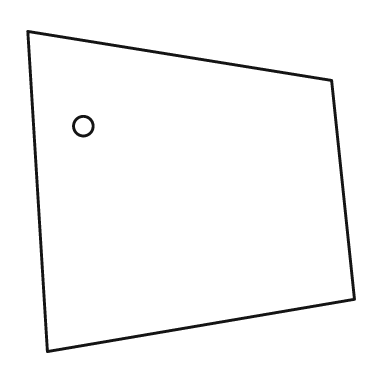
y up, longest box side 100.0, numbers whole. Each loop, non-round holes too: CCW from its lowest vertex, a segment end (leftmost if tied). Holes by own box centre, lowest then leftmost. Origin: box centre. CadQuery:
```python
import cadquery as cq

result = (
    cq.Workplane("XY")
    .moveTo(-44.0, -49.0)
    .lineTo(50.0, -33.0)
    .lineTo(43.0, 34.0)
    .lineTo(-50.0, 49.0)
    .close()
    .moveTo(-33.0, 20.0)
    .circle(3.0)
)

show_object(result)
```